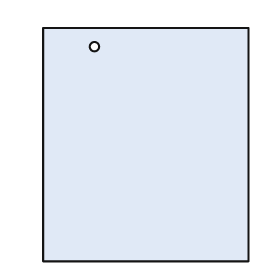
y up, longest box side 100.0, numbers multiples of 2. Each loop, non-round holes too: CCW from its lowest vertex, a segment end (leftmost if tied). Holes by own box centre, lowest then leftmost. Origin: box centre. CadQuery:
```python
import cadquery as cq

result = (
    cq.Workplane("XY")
    .moveTo(-44.0, -50.0)
    .lineTo(44.0, -50.0)
    .lineTo(44.0, 50.0)
    .lineTo(-44.0, 50.0)
    .close()
    .moveTo(-22.0, 42.0)
    .circle(2.0)
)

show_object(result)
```